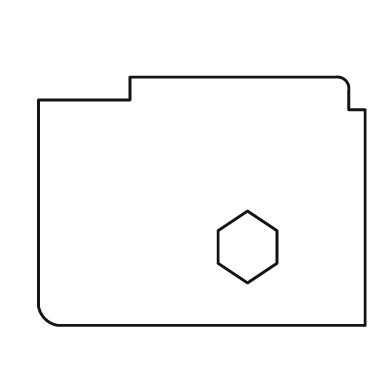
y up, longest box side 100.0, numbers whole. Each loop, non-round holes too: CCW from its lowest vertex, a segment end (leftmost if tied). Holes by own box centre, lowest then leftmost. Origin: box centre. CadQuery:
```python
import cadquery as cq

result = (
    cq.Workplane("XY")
    .moveTo(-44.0, -38.0)
    .lineTo(50.0, -38.0)
    .lineTo(50.0, 28.0)
    .lineTo(45.0, 28.0)
    .lineTo(45.0, 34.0)
    .threePointArc((44.0, 37.0), (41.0, 38.0))
    .lineTo(-22.0, 38.0)
    .lineTo(-22.0, 31.0)
    .lineTo(-50.0, 31.0)
    .lineTo(-50.0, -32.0)
    .threePointArc((-48.0, -36.0), (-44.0, -38.0))
    .close()
    .moveTo(14.0, -25.0)
    .lineTo(23.0, -19.0)
    .lineTo(23.0, -9.0)
    .lineTo(14.0, -3.0)
    .lineTo(5.0, -9.0)
    .lineTo(5.0, -19.0)
    .close()
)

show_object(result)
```